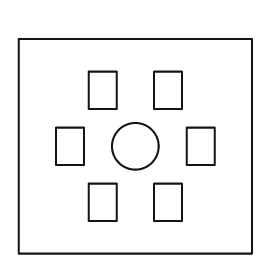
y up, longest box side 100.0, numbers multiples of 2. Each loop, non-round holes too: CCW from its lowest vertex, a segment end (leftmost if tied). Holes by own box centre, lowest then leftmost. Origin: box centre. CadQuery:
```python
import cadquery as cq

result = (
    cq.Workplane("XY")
    .moveTo(-50.0, -46.0)
    .lineTo(50.0, -46.0)
    .lineTo(50.0, 46.0)
    .lineTo(-50.0, 46.0)
    .close()
    .moveTo(-20.0, -32.0)
    .lineTo(-8.0, -32.0)
    .lineTo(-8.0, -16.0)
    .lineTo(-20.0, -16.0)
    .close()
    .moveTo(8.0, -32.0)
    .lineTo(20.0, -32.0)
    .lineTo(20.0, -16.0)
    .lineTo(8.0, -16.0)
    .close()
    .moveTo(-34.0, -8.0)
    .lineTo(-22.0, -8.0)
    .lineTo(-22.0, 8.0)
    .lineTo(-34.0, 8.0)
    .close()
    .moveTo(0.0, 0.0)
    .circle(10.0)
    .moveTo(22.0, -8.0)
    .lineTo(34.0, -8.0)
    .lineTo(34.0, 8.0)
    .lineTo(22.0, 8.0)
    .close()
    .moveTo(-20.0, 16.0)
    .lineTo(-8.0, 16.0)
    .lineTo(-8.0, 32.0)
    .lineTo(-20.0, 32.0)
    .close()
    .moveTo(8.0, 16.0)
    .lineTo(20.0, 16.0)
    .lineTo(20.0, 32.0)
    .lineTo(8.0, 32.0)
    .close()
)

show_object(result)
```